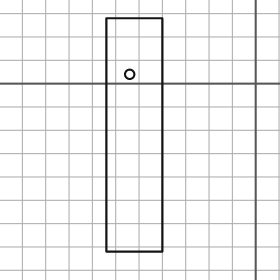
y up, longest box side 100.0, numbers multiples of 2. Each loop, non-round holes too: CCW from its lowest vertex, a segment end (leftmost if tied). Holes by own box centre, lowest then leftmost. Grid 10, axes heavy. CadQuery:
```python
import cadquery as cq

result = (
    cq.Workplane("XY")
    .moveTo(-64.0, -72.0)
    .lineTo(-40.0, -72.0)
    .lineTo(-40.0, 28.0)
    .lineTo(-64.0, 28.0)
    .close()
    .moveTo(-54.0, 4.0)
    .circle(2.0)
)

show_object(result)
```